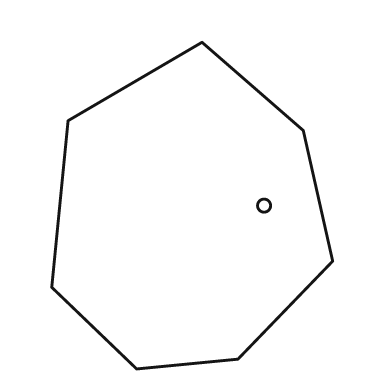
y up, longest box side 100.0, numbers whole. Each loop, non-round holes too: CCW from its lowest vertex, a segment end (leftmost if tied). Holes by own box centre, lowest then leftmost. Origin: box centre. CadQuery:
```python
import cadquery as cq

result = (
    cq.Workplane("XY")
    .moveTo(-17.0, -50.0)
    .lineTo(14.0, -47.0)
    .lineTo(43.0, -17.0)
    .lineTo(34.0, 23.0)
    .lineTo(3.0, 50.0)
    .lineTo(-38.0, 26.0)
    .lineTo(-43.0, -25.0)
    .close()
    .moveTo(22.0, 0.0)
    .circle(2.0)
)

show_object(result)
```